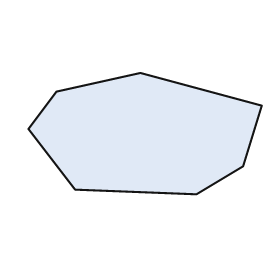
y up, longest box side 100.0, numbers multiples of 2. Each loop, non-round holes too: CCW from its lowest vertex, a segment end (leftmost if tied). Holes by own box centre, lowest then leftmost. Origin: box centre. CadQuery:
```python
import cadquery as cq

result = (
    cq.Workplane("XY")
    .moveTo(22.0, -26.0)
    .lineTo(42.0, -14.0)
    .lineTo(50.0, 12.0)
    .lineTo(-2.0, 26.0)
    .lineTo(-38.0, 18.0)
    .lineTo(-50.0, 2.0)
    .lineTo(-30.0, -24.0)
    .close()
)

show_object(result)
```